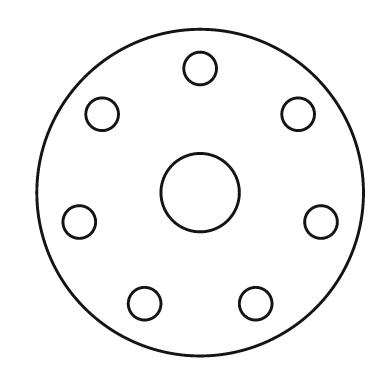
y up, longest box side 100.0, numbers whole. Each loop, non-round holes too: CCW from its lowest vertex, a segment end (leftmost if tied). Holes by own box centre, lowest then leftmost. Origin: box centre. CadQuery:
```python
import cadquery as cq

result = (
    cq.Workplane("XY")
    .moveTo(0.0, 0.0)
    .circle(50.0)
    .moveTo(-17.0, -34.0)
    .circle(5.0)
    .moveTo(17.0, -34.0)
    .circle(5.0)
    .moveTo(-37.0, -9.0)
    .circle(5.0)
    .moveTo(37.0, -9.0)
    .circle(5.0)
    .moveTo(0.0, 0.0)
    .circle(12.0)
    .moveTo(-30.0, 24.0)
    .circle(5.0)
    .moveTo(30.0, 24.0)
    .circle(5.0)
    .moveTo(0.0, 38.0)
    .circle(5.0)
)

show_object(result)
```